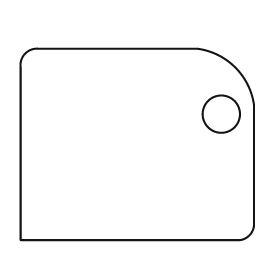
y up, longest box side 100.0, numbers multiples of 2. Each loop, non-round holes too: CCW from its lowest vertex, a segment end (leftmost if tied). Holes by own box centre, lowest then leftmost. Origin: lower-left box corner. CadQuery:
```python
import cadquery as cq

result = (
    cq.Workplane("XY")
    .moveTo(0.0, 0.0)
    .lineTo(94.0, 0.0)
    .threePointArc((98.0, 2.0), (100.0, 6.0))
    .lineTo(100.0, 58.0)
    .threePointArc((92.0, 74.0), (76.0, 82.0))
    .lineTo(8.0, 82.0)
    .threePointArc((2.0, 80.0), (0.0, 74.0))
    .close()
    .moveTo(86.0, 54.0)
    .circle(8.0)
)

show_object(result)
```